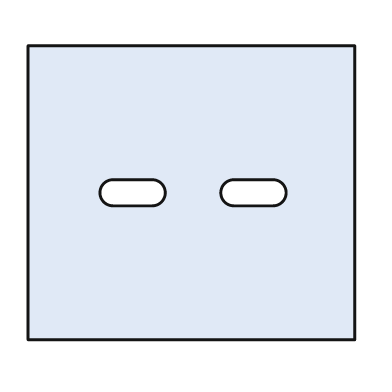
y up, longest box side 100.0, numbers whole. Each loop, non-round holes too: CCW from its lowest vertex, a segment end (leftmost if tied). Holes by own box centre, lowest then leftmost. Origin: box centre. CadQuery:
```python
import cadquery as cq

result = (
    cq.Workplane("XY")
    .moveTo(-50.0, -45.0)
    .lineTo(50.0, -45.0)
    .lineTo(50.0, 45.0)
    .lineTo(-50.0, 45.0)
    .close()
    .moveTo(-24.0, -4.0)
    .lineTo(-12.0, -4.0)
    .threePointArc((-8.0, 0.0), (-12.0, 4.0))
    .lineTo(-24.0, 4.0)
    .threePointArc((-28.0, 0.0), (-24.0, -4.0))
    .close()
    .moveTo(13.0, -4.0)
    .lineTo(25.0, -4.0)
    .threePointArc((29.0, 0.0), (25.0, 4.0))
    .lineTo(13.0, 4.0)
    .threePointArc((9.0, 0.0), (13.0, -4.0))
    .close()
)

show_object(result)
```